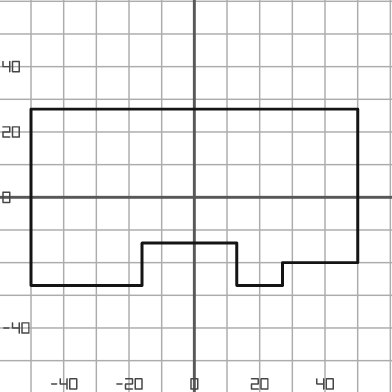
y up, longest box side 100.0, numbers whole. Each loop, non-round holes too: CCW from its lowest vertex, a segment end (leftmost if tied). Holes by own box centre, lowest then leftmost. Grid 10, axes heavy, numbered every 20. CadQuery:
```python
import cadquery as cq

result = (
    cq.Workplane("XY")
    .moveTo(-50.0, -27.0)
    .lineTo(-16.0, -27.0)
    .lineTo(-16.0, -14.0)
    .lineTo(13.0, -14.0)
    .lineTo(13.0, -27.0)
    .lineTo(27.0, -27.0)
    .lineTo(27.0, -20.0)
    .lineTo(50.0, -20.0)
    .lineTo(50.0, 27.0)
    .lineTo(-50.0, 27.0)
    .close()
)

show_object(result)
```